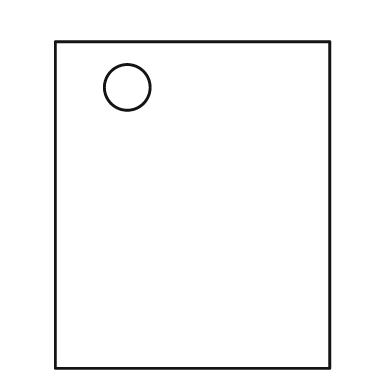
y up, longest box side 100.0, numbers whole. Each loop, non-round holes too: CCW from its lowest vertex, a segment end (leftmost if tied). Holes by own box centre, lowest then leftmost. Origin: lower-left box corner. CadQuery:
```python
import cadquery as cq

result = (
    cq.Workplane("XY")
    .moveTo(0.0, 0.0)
    .lineTo(84.0, 0.0)
    .lineTo(84.0, 100.0)
    .lineTo(0.0, 100.0)
    .close()
    .moveTo(22.0, 86.0)
    .circle(7.0)
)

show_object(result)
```